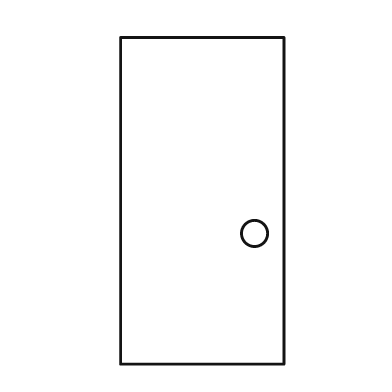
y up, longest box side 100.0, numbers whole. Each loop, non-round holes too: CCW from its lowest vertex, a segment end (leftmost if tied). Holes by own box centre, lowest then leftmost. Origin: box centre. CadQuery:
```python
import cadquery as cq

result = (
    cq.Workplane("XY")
    .moveTo(-25.0, -50.0)
    .lineTo(25.0, -50.0)
    .lineTo(25.0, 50.0)
    .lineTo(-25.0, 50.0)
    .close()
    .moveTo(16.0, -10.0)
    .circle(4.0)
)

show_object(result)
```